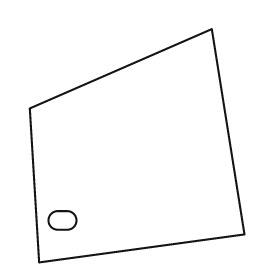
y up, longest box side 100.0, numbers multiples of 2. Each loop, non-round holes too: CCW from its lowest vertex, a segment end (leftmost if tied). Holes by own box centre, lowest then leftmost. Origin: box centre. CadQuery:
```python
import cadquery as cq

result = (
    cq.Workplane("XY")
    .moveTo(-42.0, -50.0)
    .lineTo(46.0, -38.0)
    .lineTo(32.0, 50.0)
    .lineTo(-46.0, 16.0)
    .close()
    .moveTo(-34.0, -36.0)
    .lineTo(-30.0, -36.0)
    .threePointArc((-26.0, -32.0), (-30.0, -28.0))
    .lineTo(-34.0, -28.0)
    .threePointArc((-38.0, -32.0), (-34.0, -36.0))
    .close()
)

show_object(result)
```